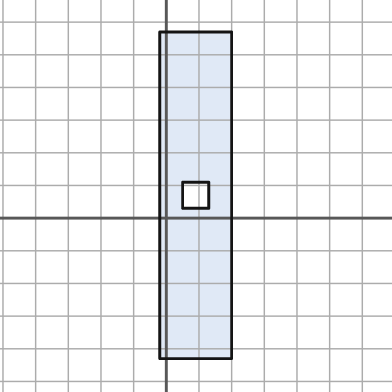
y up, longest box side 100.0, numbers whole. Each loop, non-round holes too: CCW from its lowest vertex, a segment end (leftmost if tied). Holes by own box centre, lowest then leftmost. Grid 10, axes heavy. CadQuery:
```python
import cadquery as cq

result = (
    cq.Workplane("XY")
    .moveTo(-2.0, -43.0)
    .lineTo(20.0, -43.0)
    .lineTo(20.0, 57.0)
    .lineTo(-2.0, 57.0)
    .close()
    .moveTo(5.0, 3.0)
    .lineTo(13.0, 3.0)
    .lineTo(13.0, 11.0)
    .lineTo(5.0, 11.0)
    .close()
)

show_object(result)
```